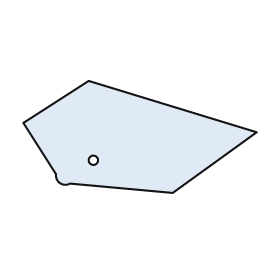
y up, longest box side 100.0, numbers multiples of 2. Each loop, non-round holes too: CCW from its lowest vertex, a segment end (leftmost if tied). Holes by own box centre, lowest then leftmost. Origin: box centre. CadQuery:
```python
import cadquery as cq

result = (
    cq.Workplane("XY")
    .moveTo(14.0, -24.0)
    .lineTo(50.0, 2.0)
    .lineTo(-22.0, 24.0)
    .lineTo(-50.0, 6.0)
    .lineTo(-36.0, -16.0)
    .threePointArc((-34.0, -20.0), (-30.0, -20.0))
    .close()
    .moveTo(-20.0, -10.0)
    .circle(2.0)
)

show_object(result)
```